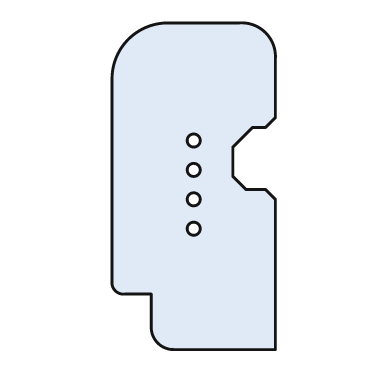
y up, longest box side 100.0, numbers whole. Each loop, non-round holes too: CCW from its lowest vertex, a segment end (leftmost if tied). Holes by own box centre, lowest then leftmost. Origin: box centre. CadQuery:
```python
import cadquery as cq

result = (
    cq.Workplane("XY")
    .moveTo(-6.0, -50.0)
    .lineTo(25.0, -50.0)
    .lineTo(25.0, -4.0)
    .lineTo(22.0, -1.0)
    .lineTo(16.0, -1.0)
    .lineTo(12.0, 3.0)
    .lineTo(12.0, 12.0)
    .lineTo(18.0, 18.0)
    .lineTo(22.0, 18.0)
    .lineTo(25.0, 21.0)
    .lineTo(25.0, 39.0)
    .threePointArc((22.0, 47.0), (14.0, 50.0))
    .lineTo(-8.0, 50.0)
    .threePointArc((-20.0, 45.0), (-25.0, 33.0))
    .lineTo(-25.0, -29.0)
    .threePointArc((-24.0, -32.0), (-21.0, -33.0))
    .lineTo(-13.0, -33.0)
    .lineTo(-13.0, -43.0)
    .threePointArc((-11.0, -48.0), (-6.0, -50.0))
    .close()
    .moveTo(0.0, -13.0)
    .circle(2.0)
    .moveTo(0.0, -4.0)
    .circle(2.0)
    .moveTo(0.0, 5.0)
    .circle(2.0)
    .moveTo(0.0, 14.0)
    .circle(2.0)
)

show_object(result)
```